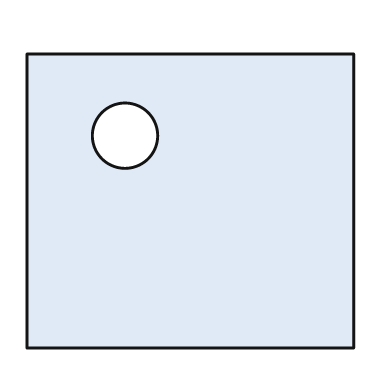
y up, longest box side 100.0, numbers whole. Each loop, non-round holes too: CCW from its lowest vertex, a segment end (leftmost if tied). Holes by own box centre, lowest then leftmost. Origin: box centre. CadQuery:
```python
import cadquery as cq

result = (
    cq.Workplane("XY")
    .moveTo(-50.0, -45.0)
    .lineTo(50.0, -45.0)
    .lineTo(50.0, 45.0)
    .lineTo(-50.0, 45.0)
    .close()
    .moveTo(-20.0, 20.0)
    .circle(10.0)
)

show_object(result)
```